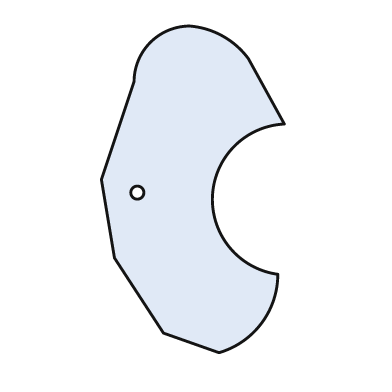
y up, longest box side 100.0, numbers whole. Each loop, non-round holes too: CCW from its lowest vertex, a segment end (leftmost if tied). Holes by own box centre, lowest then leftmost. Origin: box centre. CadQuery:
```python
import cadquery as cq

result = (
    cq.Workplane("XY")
    .moveTo(8.0, -50.0)
    .threePointArc((21.0, -41.0), (26.0, -26.0))
    .threePointArc((6.0, -2.0), (28.0, 20.0))
    .lineTo(17.0, 40.0)
    .threePointArc((9.0, 47.0), (-1.0, 50.0))
    .threePointArc((-13.0, 45.0), (-18.0, 33.0))
    .lineTo(-28.0, 3.0)
    .lineTo(-24.0, -21.0)
    .lineTo(-9.0, -44.0)
    .close()
    .moveTo(-17.0, -1.0)
    .circle(2.0)
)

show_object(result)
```